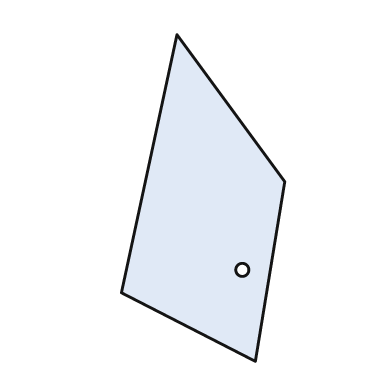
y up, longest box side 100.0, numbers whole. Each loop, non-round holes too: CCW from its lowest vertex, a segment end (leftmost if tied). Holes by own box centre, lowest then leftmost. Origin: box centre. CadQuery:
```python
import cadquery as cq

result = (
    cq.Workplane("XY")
    .moveTo(16.0, -50.0)
    .lineTo(25.0, 5.0)
    .lineTo(-8.0, 50.0)
    .lineTo(-25.0, -29.0)
    .close()
    .moveTo(12.0, -22.0)
    .circle(2.0)
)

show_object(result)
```